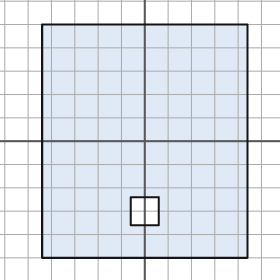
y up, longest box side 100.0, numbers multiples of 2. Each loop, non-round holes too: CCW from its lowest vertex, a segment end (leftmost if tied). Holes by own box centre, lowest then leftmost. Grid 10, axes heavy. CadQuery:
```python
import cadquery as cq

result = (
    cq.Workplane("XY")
    .moveTo(-44.0, -50.0)
    .lineTo(44.0, -50.0)
    .lineTo(44.0, 50.0)
    .lineTo(-44.0, 50.0)
    .close()
    .moveTo(-6.0, -36.0)
    .lineTo(6.0, -36.0)
    .lineTo(6.0, -24.0)
    .lineTo(-6.0, -24.0)
    .close()
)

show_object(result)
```